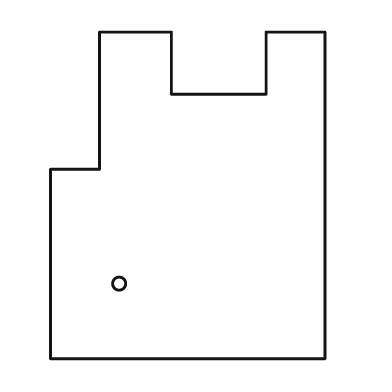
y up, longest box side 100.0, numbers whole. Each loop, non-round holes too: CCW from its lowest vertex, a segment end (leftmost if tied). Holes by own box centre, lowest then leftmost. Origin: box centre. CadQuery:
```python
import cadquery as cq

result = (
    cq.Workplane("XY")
    .moveTo(-42.0, -50.0)
    .lineTo(42.0, -50.0)
    .lineTo(42.0, 50.0)
    .lineTo(24.0, 50.0)
    .lineTo(24.0, 31.0)
    .lineTo(-5.0, 31.0)
    .lineTo(-5.0, 50.0)
    .lineTo(-27.0, 50.0)
    .lineTo(-27.0, 8.0)
    .lineTo(-42.0, 8.0)
    .close()
    .moveTo(-21.0, -27.0)
    .circle(2.0)
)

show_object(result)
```